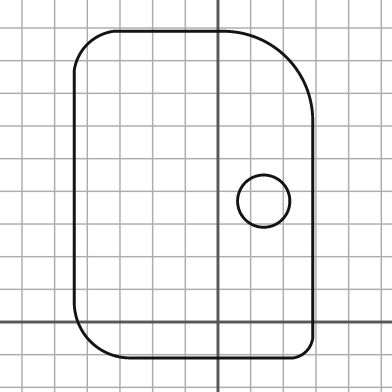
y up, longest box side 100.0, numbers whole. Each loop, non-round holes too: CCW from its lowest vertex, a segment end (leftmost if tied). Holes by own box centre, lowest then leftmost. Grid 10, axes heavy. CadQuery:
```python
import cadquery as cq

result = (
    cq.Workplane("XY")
    .moveTo(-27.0, -11.0)
    .lineTo(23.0, -11.0)
    .threePointArc((27.0, -9.0), (29.0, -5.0))
    .lineTo(29.0, 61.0)
    .threePointArc((21.0, 81.0), (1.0, 89.0))
    .lineTo(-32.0, 89.0)
    .threePointArc((-40.0, 85.0), (-44.0, 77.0))
    .lineTo(-44.0, 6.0)
    .threePointArc((-39.0, -6.0), (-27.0, -11.0))
    .close()
    .moveTo(14.0, 37.0)
    .circle(8.0)
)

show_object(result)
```